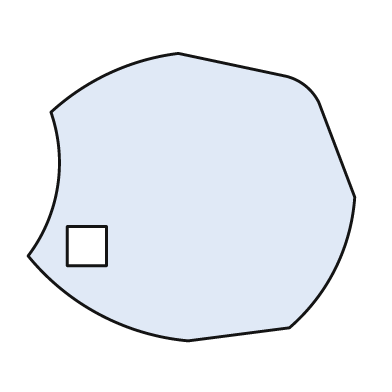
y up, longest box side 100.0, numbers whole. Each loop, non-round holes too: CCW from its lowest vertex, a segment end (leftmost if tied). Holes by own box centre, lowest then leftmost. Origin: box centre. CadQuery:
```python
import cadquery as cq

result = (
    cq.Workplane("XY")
    .moveTo(-1.0, -44.0)
    .lineTo(30.0, -40.0)
    .threePointArc((44.0, -22.0), (50.0, 0.0))
    .lineTo(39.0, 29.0)
    .threePointArc((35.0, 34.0), (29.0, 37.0))
    .lineTo(-4.0, 44.0)
    .threePointArc((-25.0, 38.0), (-43.0, 26.0))
    .threePointArc((-41.0, 3.0), (-50.0, -18.0))
    .threePointArc((-28.0, -36.0), (-1.0, -44.0))
    .close()
    .moveTo(-38.0, -21.0)
    .lineTo(-26.0, -21.0)
    .lineTo(-26.0, -9.0)
    .lineTo(-38.0, -9.0)
    .close()
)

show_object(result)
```